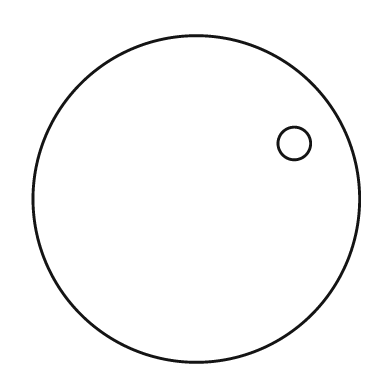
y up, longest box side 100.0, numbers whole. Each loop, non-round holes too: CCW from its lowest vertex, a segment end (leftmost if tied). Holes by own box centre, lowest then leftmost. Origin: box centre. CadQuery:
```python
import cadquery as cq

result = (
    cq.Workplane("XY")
    .moveTo(0.0, 0.0)
    .circle(50.0)
    .moveTo(30.0, 17.0)
    .circle(5.0)
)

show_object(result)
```